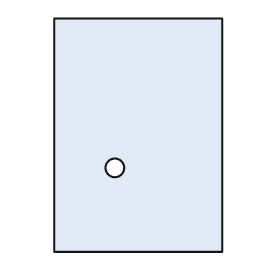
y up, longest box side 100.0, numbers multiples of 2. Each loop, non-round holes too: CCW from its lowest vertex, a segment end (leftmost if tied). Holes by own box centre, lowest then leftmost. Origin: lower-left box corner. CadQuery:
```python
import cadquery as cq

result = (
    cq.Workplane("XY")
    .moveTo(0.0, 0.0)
    .lineTo(72.0, 0.0)
    .lineTo(72.0, 100.0)
    .lineTo(0.0, 100.0)
    .close()
    .moveTo(26.0, 36.0)
    .circle(4.0)
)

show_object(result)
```